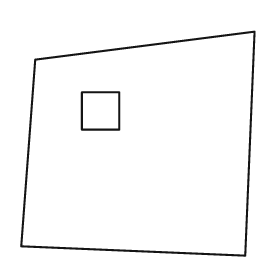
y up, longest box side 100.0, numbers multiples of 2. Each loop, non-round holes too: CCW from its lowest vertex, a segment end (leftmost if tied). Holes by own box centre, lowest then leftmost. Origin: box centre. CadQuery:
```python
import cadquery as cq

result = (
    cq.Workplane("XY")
    .moveTo(46.0, -48.0)
    .lineTo(50.0, 48.0)
    .lineTo(-44.0, 36.0)
    .lineTo(-50.0, -44.0)
    .close()
    .moveTo(-24.0, 6.0)
    .lineTo(-8.0, 6.0)
    .lineTo(-8.0, 22.0)
    .lineTo(-24.0, 22.0)
    .close()
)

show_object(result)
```